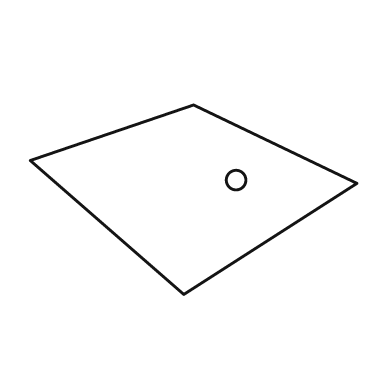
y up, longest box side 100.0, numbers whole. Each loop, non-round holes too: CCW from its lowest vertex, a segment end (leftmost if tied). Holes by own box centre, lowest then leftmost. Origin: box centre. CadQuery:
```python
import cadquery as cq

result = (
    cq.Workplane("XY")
    .moveTo(-3.0, -29.0)
    .lineTo(50.0, 5.0)
    .lineTo(0.0, 29.0)
    .lineTo(-50.0, 12.0)
    .close()
    .moveTo(13.0, 6.0)
    .circle(3.0)
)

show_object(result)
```